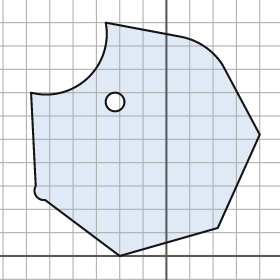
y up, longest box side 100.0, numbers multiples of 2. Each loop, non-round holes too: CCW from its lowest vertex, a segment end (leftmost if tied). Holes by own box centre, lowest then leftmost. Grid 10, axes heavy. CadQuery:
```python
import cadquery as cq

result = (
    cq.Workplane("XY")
    .moveTo(-20.0, 0.0)
    .lineTo(22.0, 12.0)
    .lineTo(40.0, 52.0)
    .lineTo(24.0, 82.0)
    .threePointArc((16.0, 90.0), (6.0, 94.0))
    .lineTo(-26.0, 100.0)
    .threePointArc((-34.0, 76.0), (-58.0, 70.0))
    .lineTo(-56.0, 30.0)
    .threePointArc((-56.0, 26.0), (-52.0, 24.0))
    .close()
    .moveTo(-22.0, 66.0)
    .circle(4.0)
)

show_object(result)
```